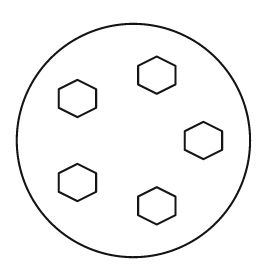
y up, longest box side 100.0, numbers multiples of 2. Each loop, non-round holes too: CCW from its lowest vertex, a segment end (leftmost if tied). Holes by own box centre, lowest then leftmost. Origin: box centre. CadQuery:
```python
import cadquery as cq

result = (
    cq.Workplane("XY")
    .moveTo(0.0, 0.0)
    .circle(50.0)
    .moveTo(10.0, -36.0)
    .lineTo(18.0, -32.0)
    .lineTo(18.0, -24.0)
    .lineTo(10.0, -20.0)
    .lineTo(2.0, -24.0)
    .lineTo(2.0, -32.0)
    .close()
    .moveTo(-24.0, -26.0)
    .lineTo(-16.0, -22.0)
    .lineTo(-16.0, -14.0)
    .lineTo(-24.0, -10.0)
    .lineTo(-32.0, -14.0)
    .lineTo(-32.0, -22.0)
    .close()
    .moveTo(30.0, -8.0)
    .lineTo(38.0, -4.0)
    .lineTo(38.0, 4.0)
    .lineTo(30.0, 8.0)
    .lineTo(22.0, 4.0)
    .lineTo(22.0, -4.0)
    .close()
    .moveTo(-24.0, 10.0)
    .lineTo(-16.0, 14.0)
    .lineTo(-16.0, 22.0)
    .lineTo(-24.0, 26.0)
    .lineTo(-32.0, 22.0)
    .lineTo(-32.0, 14.0)
    .close()
    .moveTo(10.0, 20.0)
    .lineTo(18.0, 24.0)
    .lineTo(18.0, 32.0)
    .lineTo(10.0, 36.0)
    .lineTo(2.0, 32.0)
    .lineTo(2.0, 24.0)
    .close()
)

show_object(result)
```